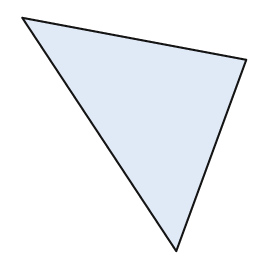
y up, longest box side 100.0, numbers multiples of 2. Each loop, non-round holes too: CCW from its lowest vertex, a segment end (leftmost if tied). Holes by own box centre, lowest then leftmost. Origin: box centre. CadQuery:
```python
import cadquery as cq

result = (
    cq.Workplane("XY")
    .moveTo(18.0, -50.0)
    .lineTo(48.0, 32.0)
    .lineTo(-48.0, 50.0)
    .close()
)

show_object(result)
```